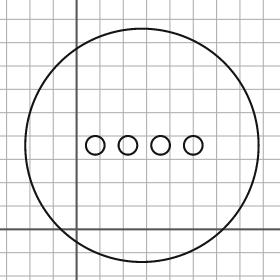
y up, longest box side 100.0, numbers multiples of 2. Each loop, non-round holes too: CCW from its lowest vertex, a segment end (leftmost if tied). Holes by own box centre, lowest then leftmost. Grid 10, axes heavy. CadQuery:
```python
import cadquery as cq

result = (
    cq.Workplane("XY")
    .moveTo(28.0, 36.0)
    .circle(50.0)
    .moveTo(8.0, 36.0)
    .circle(4.0)
    .moveTo(22.0, 36.0)
    .circle(4.0)
    .moveTo(36.0, 36.0)
    .circle(4.0)
    .moveTo(50.0, 36.0)
    .circle(4.0)
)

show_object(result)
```